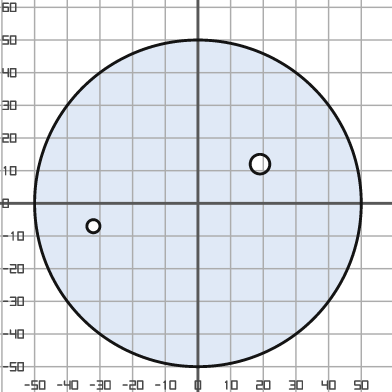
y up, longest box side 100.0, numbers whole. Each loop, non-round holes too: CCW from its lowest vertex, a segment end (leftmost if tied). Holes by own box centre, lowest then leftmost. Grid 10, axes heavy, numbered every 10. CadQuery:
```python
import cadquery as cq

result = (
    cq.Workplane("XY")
    .moveTo(0.0, 0.0)
    .circle(50.0)
    .moveTo(-32.0, -7.0)
    .circle(2.0)
    .moveTo(19.0, 12.0)
    .circle(3.0)
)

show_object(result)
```